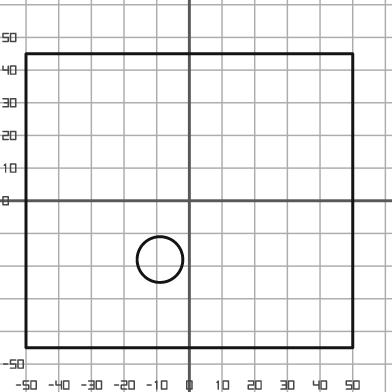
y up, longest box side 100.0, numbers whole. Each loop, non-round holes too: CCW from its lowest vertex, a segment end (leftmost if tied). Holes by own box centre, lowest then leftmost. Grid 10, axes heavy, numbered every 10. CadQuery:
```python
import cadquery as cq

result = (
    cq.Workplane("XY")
    .moveTo(-50.0, -45.0)
    .lineTo(50.0, -45.0)
    .lineTo(50.0, 45.0)
    .lineTo(-50.0, 45.0)
    .close()
    .moveTo(-9.0, -18.0)
    .circle(7.0)
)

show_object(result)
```